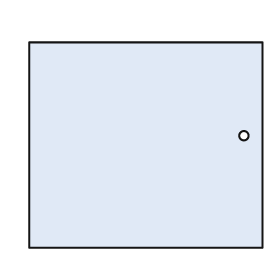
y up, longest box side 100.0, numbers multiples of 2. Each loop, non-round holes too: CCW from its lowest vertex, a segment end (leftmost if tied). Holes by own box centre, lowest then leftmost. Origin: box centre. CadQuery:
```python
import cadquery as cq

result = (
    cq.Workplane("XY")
    .moveTo(-50.0, -44.0)
    .lineTo(50.0, -44.0)
    .lineTo(50.0, 44.0)
    .lineTo(-50.0, 44.0)
    .close()
    .moveTo(42.0, 4.0)
    .circle(2.0)
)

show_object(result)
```